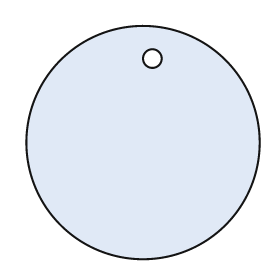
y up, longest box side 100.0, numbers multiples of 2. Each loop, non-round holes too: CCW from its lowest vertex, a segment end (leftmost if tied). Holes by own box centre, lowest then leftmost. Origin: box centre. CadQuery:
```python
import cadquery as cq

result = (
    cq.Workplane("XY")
    .moveTo(0.0, 0.0)
    .circle(50.0)
    .moveTo(4.0, 36.0)
    .circle(4.0)
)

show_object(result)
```